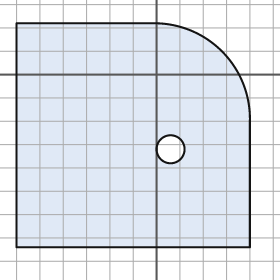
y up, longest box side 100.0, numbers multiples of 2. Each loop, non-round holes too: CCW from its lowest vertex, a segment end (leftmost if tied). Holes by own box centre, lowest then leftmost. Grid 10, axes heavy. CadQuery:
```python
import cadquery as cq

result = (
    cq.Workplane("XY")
    .moveTo(-60.0, -74.0)
    .lineTo(40.0, -74.0)
    .lineTo(40.0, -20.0)
    .threePointArc((28.0, 10.0), (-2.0, 22.0))
    .lineTo(-60.0, 22.0)
    .close()
    .moveTo(6.0, -32.0)
    .circle(6.0)
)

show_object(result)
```